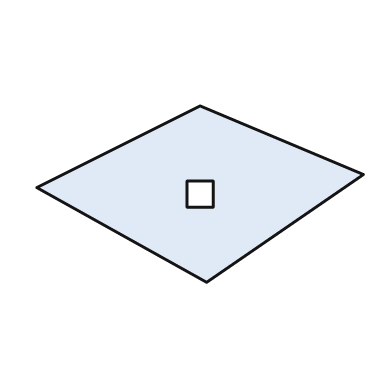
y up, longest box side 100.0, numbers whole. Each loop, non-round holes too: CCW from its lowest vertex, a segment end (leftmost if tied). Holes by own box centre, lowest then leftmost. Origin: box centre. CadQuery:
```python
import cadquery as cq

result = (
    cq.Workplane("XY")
    .moveTo(2.0, -27.0)
    .lineTo(50.0, 6.0)
    .lineTo(0.0, 27.0)
    .lineTo(-50.0, 2.0)
    .close()
    .moveTo(-4.0, -4.0)
    .lineTo(4.0, -4.0)
    .lineTo(4.0, 4.0)
    .lineTo(-4.0, 4.0)
    .close()
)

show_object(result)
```